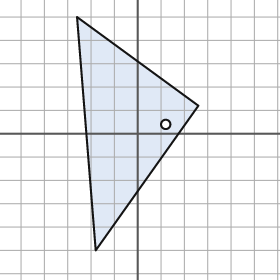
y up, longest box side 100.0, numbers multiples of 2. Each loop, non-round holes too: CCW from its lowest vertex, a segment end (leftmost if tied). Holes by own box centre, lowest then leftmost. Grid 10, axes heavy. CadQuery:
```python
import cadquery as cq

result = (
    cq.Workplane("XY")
    .moveTo(-18.0, -50.0)
    .lineTo(26.0, 12.0)
    .lineTo(-26.0, 50.0)
    .close()
    .moveTo(12.0, 4.0)
    .circle(2.0)
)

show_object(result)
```